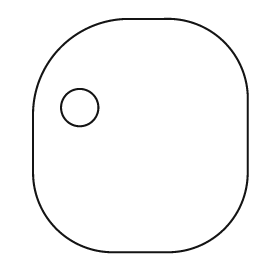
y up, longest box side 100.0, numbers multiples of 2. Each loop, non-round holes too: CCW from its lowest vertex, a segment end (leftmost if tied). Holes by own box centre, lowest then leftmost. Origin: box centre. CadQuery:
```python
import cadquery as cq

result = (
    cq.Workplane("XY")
    .moveTo(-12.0, -50.0)
    .lineTo(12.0, -50.0)
    .threePointArc((36.0, -40.0), (46.0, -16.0))
    .lineTo(46.0, 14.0)
    .threePointArc((36.0, 40.0), (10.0, 50.0))
    .lineTo(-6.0, 50.0)
    .threePointArc((-34.0, 38.0), (-46.0, 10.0))
    .lineTo(-46.0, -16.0)
    .threePointArc((-36.0, -40.0), (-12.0, -50.0))
    .close()
    .moveTo(-26.0, 12.0)
    .circle(8.0)
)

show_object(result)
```